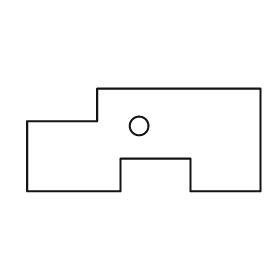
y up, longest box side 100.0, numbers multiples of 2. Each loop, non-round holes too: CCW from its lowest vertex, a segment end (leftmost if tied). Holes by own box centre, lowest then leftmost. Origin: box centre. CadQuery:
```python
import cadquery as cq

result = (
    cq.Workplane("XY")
    .moveTo(-50.0, -22.0)
    .lineTo(-10.0, -22.0)
    .lineTo(-10.0, -8.0)
    .lineTo(20.0, -8.0)
    .lineTo(20.0, -22.0)
    .lineTo(50.0, -22.0)
    .lineTo(50.0, 22.0)
    .lineTo(-20.0, 22.0)
    .lineTo(-20.0, 8.0)
    .lineTo(-50.0, 8.0)
    .close()
    .moveTo(-2.0, 6.0)
    .circle(4.0)
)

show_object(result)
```